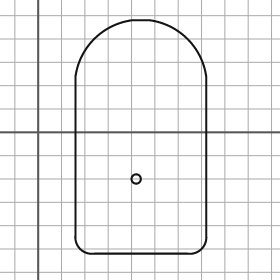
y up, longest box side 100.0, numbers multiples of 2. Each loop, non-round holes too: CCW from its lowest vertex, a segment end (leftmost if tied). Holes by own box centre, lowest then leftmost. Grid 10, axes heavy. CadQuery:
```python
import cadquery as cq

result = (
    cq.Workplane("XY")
    .moveTo(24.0, -52.0)
    .lineTo(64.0, -52.0)
    .threePointArc((70.0, -50.0), (72.0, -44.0))
    .lineTo(72.0, 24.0)
    .threePointArc((64.0, 40.0), (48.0, 48.0))
    .lineTo(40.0, 48.0)
    .threePointArc((24.0, 40.0), (16.0, 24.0))
    .lineTo(16.0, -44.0)
    .threePointArc((18.0, -50.0), (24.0, -52.0))
    .close()
    .moveTo(42.0, -20.0)
    .circle(2.0)
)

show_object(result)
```